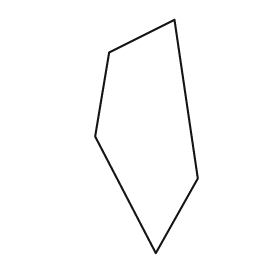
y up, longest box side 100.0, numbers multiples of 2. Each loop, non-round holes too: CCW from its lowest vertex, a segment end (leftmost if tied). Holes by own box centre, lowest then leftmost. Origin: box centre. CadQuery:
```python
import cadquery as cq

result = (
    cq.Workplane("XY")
    .moveTo(4.0, -50.0)
    .lineTo(22.0, -18.0)
    .lineTo(12.0, 50.0)
    .lineTo(-16.0, 36.0)
    .lineTo(-22.0, 0.0)
    .close()
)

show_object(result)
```